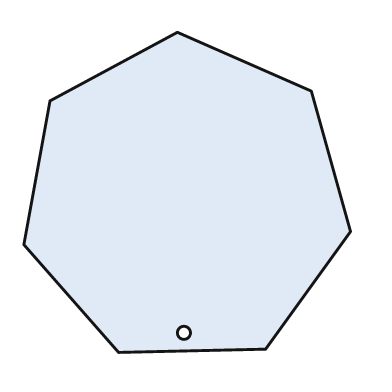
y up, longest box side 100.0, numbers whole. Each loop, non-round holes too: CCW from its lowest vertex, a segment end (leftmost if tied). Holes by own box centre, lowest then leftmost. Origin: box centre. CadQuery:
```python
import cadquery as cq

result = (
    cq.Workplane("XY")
    .moveTo(-21.0, -49.0)
    .lineTo(24.0, -48.0)
    .lineTo(50.0, -12.0)
    .lineTo(38.0, 31.0)
    .lineTo(-3.0, 49.0)
    .lineTo(-42.0, 28.0)
    .lineTo(-50.0, -16.0)
    .close()
    .moveTo(-1.0, -43.0)
    .circle(2.0)
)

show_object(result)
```